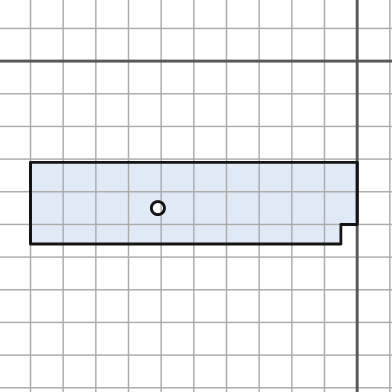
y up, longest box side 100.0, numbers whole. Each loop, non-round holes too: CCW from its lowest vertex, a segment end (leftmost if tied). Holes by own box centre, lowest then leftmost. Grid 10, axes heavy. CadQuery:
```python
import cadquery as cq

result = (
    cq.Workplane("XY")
    .moveTo(-100.0, -56.0)
    .lineTo(-5.0, -56.0)
    .lineTo(-5.0, -50.0)
    .lineTo(0.0, -50.0)
    .lineTo(0.0, -31.0)
    .lineTo(-100.0, -31.0)
    .close()
    .moveTo(-61.0, -45.0)
    .circle(2.0)
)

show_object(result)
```